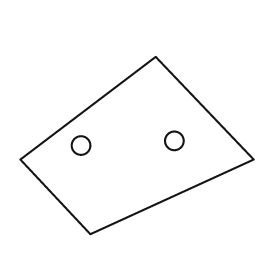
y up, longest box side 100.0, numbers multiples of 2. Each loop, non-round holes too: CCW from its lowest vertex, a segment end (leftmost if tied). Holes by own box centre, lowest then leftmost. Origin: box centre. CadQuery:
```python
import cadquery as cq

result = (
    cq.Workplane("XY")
    .moveTo(-20.0, -38.0)
    .lineTo(50.0, -6.0)
    .lineTo(8.0, 38.0)
    .lineTo(-50.0, -6.0)
    .close()
    .moveTo(-24.0, 0.0)
    .circle(4.0)
    .moveTo(16.0, 2.0)
    .circle(4.0)
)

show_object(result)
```